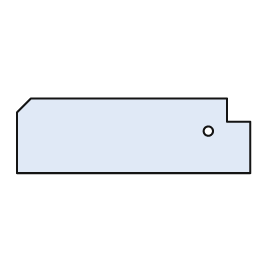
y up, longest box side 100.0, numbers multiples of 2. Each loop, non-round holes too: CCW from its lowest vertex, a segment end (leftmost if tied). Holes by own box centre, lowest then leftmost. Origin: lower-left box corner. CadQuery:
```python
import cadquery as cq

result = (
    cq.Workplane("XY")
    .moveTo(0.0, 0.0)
    .lineTo(100.0, 0.0)
    .lineTo(100.0, 22.0)
    .lineTo(90.0, 22.0)
    .lineTo(90.0, 32.0)
    .lineTo(6.0, 32.0)
    .lineTo(0.0, 26.0)
    .close()
    .moveTo(82.0, 18.0)
    .circle(2.0)
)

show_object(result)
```